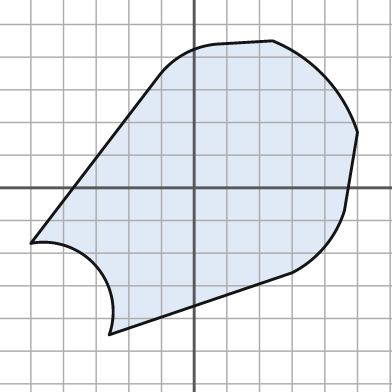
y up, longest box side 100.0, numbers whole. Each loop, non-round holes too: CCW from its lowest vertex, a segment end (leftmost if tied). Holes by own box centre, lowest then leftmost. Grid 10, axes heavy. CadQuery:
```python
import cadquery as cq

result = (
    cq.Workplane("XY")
    .moveTo(-26.0, -45.0)
    .lineTo(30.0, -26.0)
    .threePointArc((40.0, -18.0), (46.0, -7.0))
    .lineTo(50.0, 17.0)
    .threePointArc((40.0, 34.0), (24.0, 45.0))
    .lineTo(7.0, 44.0)
    .threePointArc((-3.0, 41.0), (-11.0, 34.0))
    .lineTo(-50.0, -17.0)
    .threePointArc((-30.0, -24.0), (-26.0, -45.0))
    .close()
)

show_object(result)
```